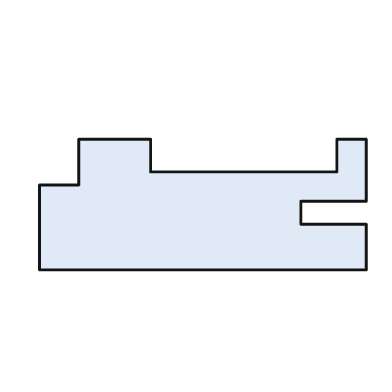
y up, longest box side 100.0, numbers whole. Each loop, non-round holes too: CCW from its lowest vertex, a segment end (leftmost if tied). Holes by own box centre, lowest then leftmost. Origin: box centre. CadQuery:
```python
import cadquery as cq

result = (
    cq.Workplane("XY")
    .moveTo(-50.0, -20.0)
    .lineTo(50.0, -20.0)
    .lineTo(50.0, -6.0)
    .lineTo(30.0, -6.0)
    .lineTo(30.0, 1.0)
    .lineTo(50.0, 1.0)
    .lineTo(50.0, 20.0)
    .lineTo(41.0, 20.0)
    .lineTo(41.0, 10.0)
    .lineTo(-16.0, 10.0)
    .lineTo(-16.0, 20.0)
    .lineTo(-38.0, 20.0)
    .lineTo(-38.0, 6.0)
    .lineTo(-50.0, 6.0)
    .close()
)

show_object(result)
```